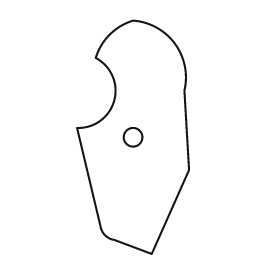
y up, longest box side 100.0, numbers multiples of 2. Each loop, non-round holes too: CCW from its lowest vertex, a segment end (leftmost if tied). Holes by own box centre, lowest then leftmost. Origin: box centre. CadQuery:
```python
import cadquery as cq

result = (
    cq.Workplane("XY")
    .moveTo(8.0, -50.0)
    .lineTo(24.0, -14.0)
    .lineTo(22.0, 20.0)
    .threePointArc((18.0, 40.0), (0.0, 50.0))
    .threePointArc((-10.0, 44.0), (-16.0, 34.0))
    .threePointArc((-8.0, 16.0), (-24.0, 4.0))
    .lineTo(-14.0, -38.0)
    .threePointArc((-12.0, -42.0), (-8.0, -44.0))
    .close()
    .moveTo(0.0, 0.0)
    .circle(4.0)
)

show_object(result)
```